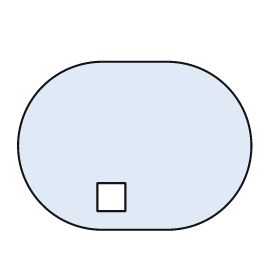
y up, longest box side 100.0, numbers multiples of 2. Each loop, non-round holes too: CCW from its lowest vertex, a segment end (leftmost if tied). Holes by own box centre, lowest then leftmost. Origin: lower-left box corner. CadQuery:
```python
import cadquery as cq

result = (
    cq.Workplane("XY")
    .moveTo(36.0, 0.0)
    .lineTo(64.0, 0.0)
    .threePointArc((100.0, 36.0), (64.0, 72.0))
    .lineTo(36.0, 72.0)
    .threePointArc((0.0, 36.0), (36.0, 0.0))
    .close()
    .moveTo(34.0, 8.0)
    .lineTo(46.0, 8.0)
    .lineTo(46.0, 20.0)
    .lineTo(34.0, 20.0)
    .close()
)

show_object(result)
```